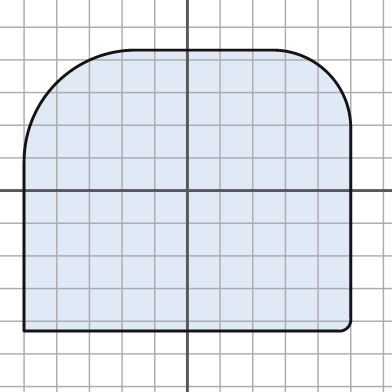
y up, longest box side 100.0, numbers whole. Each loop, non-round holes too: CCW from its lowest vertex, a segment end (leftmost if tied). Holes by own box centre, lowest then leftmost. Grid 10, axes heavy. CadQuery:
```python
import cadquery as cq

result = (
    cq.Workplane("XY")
    .moveTo(-50.0, -43.0)
    .lineTo(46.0, -43.0)
    .threePointArc((49.0, -42.0), (50.0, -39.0))
    .lineTo(50.0, 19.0)
    .threePointArc((43.0, 36.0), (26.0, 43.0))
    .lineTo(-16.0, 43.0)
    .threePointArc((-40.0, 33.0), (-50.0, 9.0))
    .close()
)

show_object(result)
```